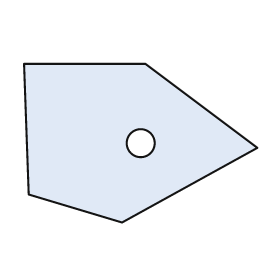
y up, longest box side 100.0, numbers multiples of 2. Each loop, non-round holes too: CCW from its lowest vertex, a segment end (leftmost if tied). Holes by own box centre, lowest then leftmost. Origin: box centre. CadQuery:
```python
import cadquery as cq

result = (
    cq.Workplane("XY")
    .moveTo(-8.0, -34.0)
    .lineTo(50.0, -2.0)
    .lineTo(2.0, 34.0)
    .lineTo(-50.0, 34.0)
    .lineTo(-48.0, -22.0)
    .close()
    .moveTo(0.0, 0.0)
    .circle(6.0)
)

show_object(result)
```